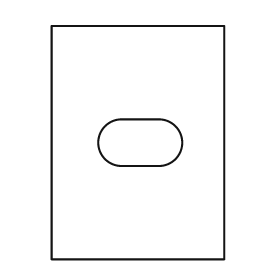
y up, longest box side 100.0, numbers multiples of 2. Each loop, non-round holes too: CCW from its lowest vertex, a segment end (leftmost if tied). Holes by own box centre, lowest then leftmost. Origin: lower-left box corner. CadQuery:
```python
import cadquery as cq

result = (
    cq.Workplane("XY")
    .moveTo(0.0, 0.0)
    .lineTo(74.0, 0.0)
    .lineTo(74.0, 100.0)
    .lineTo(0.0, 100.0)
    .close()
    .moveTo(30.0, 40.0)
    .lineTo(46.0, 40.0)
    .threePointArc((56.0, 50.0), (46.0, 60.0))
    .lineTo(30.0, 60.0)
    .threePointArc((20.0, 50.0), (30.0, 40.0))
    .close()
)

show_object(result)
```